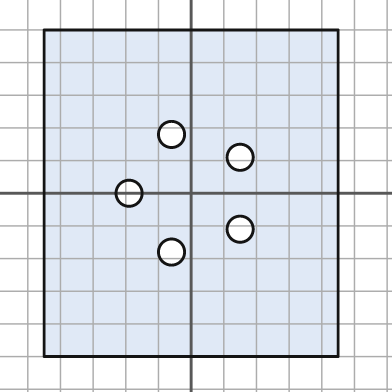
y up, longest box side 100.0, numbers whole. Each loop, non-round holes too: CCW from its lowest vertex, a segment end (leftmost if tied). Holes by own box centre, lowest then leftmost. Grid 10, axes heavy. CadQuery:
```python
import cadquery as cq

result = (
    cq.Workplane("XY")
    .moveTo(-45.0, -50.0)
    .lineTo(45.0, -50.0)
    .lineTo(45.0, 50.0)
    .lineTo(-45.0, 50.0)
    .close()
    .moveTo(-6.0, -18.0)
    .circle(4.0)
    .moveTo(15.0, -11.0)
    .circle(4.0)
    .moveTo(-19.0, 0.0)
    .circle(4.0)
    .moveTo(15.0, 11.0)
    .circle(4.0)
    .moveTo(-6.0, 18.0)
    .circle(4.0)
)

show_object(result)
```